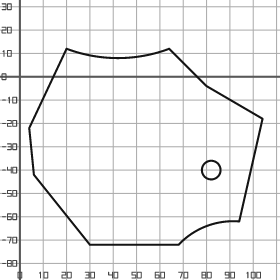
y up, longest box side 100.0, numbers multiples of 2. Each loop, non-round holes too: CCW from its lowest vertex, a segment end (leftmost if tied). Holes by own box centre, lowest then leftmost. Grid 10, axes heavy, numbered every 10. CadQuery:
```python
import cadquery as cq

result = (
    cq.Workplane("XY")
    .moveTo(30.0, -72.0)
    .lineTo(68.0, -72.0)
    .threePointArc((80.0, -64.0), (94.0, -62.0))
    .lineTo(104.0, -18.0)
    .lineTo(80.0, -4.0)
    .lineTo(64.0, 12.0)
    .threePointArc((42.0, 8.0), (20.0, 12.0))
    .lineTo(4.0, -22.0)
    .lineTo(6.0, -42.0)
    .close()
    .moveTo(82.0, -40.0)
    .circle(4.0)
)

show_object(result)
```